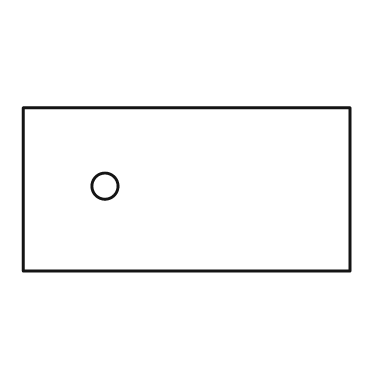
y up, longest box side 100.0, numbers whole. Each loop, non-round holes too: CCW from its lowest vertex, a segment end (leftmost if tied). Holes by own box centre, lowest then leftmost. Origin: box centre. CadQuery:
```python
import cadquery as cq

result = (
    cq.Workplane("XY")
    .moveTo(-50.0, -25.0)
    .lineTo(50.0, -25.0)
    .lineTo(50.0, 25.0)
    .lineTo(-50.0, 25.0)
    .close()
    .moveTo(-25.0, 1.0)
    .circle(4.0)
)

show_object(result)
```